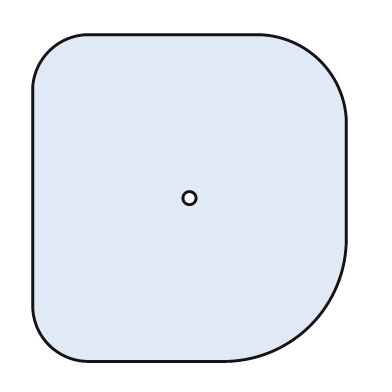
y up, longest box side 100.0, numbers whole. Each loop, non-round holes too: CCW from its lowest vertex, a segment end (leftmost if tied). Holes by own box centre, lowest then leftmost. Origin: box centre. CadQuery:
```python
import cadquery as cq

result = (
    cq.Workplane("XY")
    .moveTo(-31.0, -50.0)
    .lineTo(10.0, -50.0)
    .threePointArc((37.0, -39.0), (48.0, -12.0))
    .lineTo(48.0, 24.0)
    .threePointArc((40.0, 42.0), (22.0, 50.0))
    .lineTo(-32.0, 50.0)
    .threePointArc((-43.0, 45.0), (-48.0, 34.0))
    .lineTo(-48.0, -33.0)
    .threePointArc((-43.0, -45.0), (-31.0, -50.0))
    .close()
    .moveTo(0.0, 0.0)
    .circle(2.0)
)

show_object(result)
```